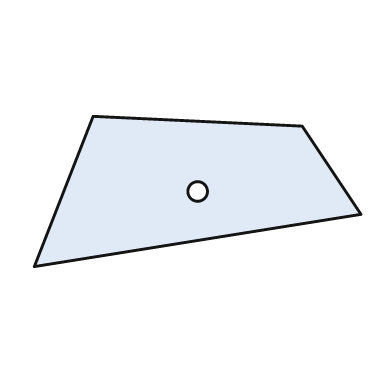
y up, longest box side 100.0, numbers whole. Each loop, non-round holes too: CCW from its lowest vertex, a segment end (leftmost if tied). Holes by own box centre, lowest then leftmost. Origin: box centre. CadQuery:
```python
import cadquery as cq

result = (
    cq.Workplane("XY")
    .moveTo(-50.0, -23.0)
    .lineTo(50.0, -7.0)
    .lineTo(32.0, 20.0)
    .lineTo(-32.0, 23.0)
    .close()
    .moveTo(0.0, 0.0)
    .circle(3.0)
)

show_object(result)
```